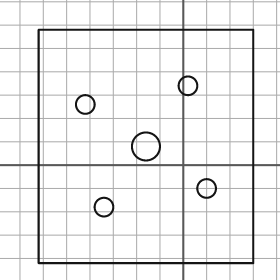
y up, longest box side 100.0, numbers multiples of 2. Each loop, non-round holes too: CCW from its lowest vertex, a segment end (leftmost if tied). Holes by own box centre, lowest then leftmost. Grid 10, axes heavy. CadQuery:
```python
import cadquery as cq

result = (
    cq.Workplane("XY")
    .moveTo(-62.0, -42.0)
    .lineTo(30.0, -42.0)
    .lineTo(30.0, 58.0)
    .lineTo(-62.0, 58.0)
    .close()
    .moveTo(-34.0, -18.0)
    .circle(4.0)
    .moveTo(10.0, -10.0)
    .circle(4.0)
    .moveTo(-16.0, 8.0)
    .circle(6.0)
    .moveTo(-42.0, 26.0)
    .circle(4.0)
    .moveTo(2.0, 34.0)
    .circle(4.0)
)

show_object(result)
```